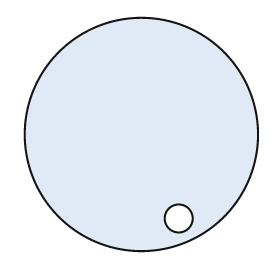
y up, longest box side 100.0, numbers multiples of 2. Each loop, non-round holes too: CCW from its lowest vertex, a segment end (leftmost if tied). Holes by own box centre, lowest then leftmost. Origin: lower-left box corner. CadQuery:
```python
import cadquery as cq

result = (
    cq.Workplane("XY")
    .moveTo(50.0, 50.0)
    .circle(50.0)
    .moveTo(66.0, 14.0)
    .circle(6.0)
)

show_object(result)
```